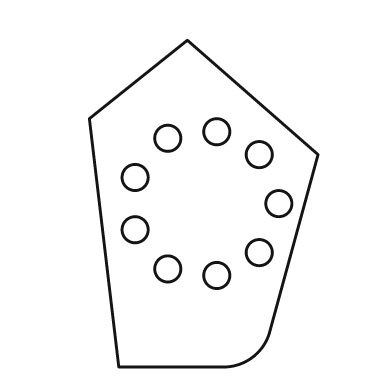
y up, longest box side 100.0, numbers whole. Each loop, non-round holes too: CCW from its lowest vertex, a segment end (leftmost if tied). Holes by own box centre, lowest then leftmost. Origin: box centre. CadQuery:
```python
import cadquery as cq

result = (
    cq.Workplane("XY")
    .moveTo(-26.0, -50.0)
    .lineTo(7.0, -50.0)
    .threePointArc((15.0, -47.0), (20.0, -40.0))
    .lineTo(35.0, 15.0)
    .lineTo(-5.0, 50.0)
    .lineTo(-35.0, 26.0)
    .close()
    .moveTo(4.0, -22.0)
    .circle(4.0)
    .moveTo(-11.0, -20.0)
    .circle(4.0)
    .moveTo(17.0, -15.0)
    .circle(4.0)
    .moveTo(-21.0, -8.0)
    .circle(4.0)
    .moveTo(23.0, 0.0)
    .circle(4.0)
    .moveTo(-21.0, 8.0)
    .circle(4.0)
    .moveTo(17.0, 15.0)
    .circle(4.0)
    .moveTo(-11.0, 20.0)
    .circle(4.0)
    .moveTo(4.0, 22.0)
    .circle(4.0)
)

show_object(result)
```